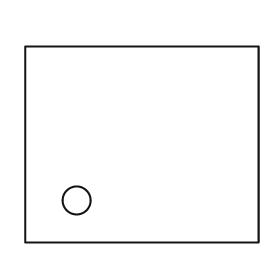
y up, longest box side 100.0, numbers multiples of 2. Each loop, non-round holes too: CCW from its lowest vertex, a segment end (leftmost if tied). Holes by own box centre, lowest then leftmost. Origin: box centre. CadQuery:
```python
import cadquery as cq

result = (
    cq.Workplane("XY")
    .moveTo(-50.0, -42.0)
    .lineTo(50.0, -42.0)
    .lineTo(50.0, 42.0)
    .lineTo(-50.0, 42.0)
    .close()
    .moveTo(-28.0, -24.0)
    .circle(6.0)
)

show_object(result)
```